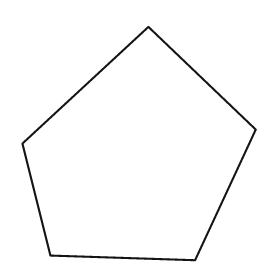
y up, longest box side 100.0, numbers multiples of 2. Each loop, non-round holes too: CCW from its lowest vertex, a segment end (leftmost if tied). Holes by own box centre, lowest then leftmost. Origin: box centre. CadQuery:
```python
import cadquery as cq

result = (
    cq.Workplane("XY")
    .moveTo(24.0, -50.0)
    .lineTo(50.0, 6.0)
    .lineTo(4.0, 50.0)
    .lineTo(-50.0, 0.0)
    .lineTo(-38.0, -48.0)
    .close()
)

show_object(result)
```